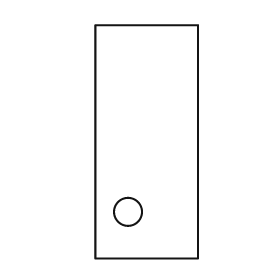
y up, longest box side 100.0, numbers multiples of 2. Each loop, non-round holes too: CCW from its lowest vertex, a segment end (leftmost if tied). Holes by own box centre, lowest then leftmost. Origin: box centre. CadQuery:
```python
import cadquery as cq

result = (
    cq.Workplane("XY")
    .moveTo(-22.0, -50.0)
    .lineTo(22.0, -50.0)
    .lineTo(22.0, 50.0)
    .lineTo(-22.0, 50.0)
    .close()
    .moveTo(-8.0, -30.0)
    .circle(6.0)
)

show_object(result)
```